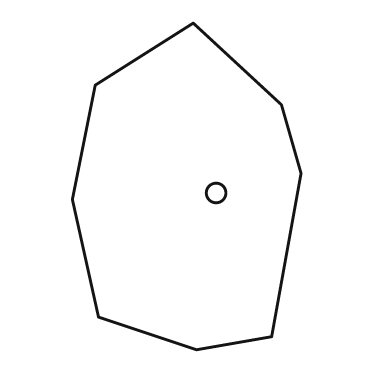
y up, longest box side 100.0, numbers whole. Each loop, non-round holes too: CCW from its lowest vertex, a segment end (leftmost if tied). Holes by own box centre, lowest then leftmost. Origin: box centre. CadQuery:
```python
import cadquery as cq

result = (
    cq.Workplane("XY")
    .moveTo(3.0, -50.0)
    .lineTo(26.0, -46.0)
    .lineTo(35.0, 4.0)
    .lineTo(29.0, 25.0)
    .lineTo(2.0, 50.0)
    .lineTo(-28.0, 31.0)
    .lineTo(-35.0, -4.0)
    .lineTo(-27.0, -40.0)
    .close()
    .moveTo(9.0, -2.0)
    .circle(3.0)
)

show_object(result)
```